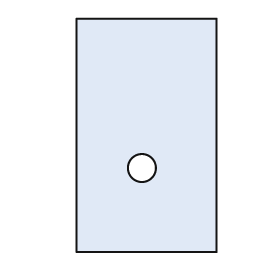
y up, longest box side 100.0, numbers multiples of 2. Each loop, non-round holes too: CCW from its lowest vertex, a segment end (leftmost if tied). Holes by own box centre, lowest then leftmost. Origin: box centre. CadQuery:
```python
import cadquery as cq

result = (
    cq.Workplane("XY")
    .moveTo(-30.0, -50.0)
    .lineTo(30.0, -50.0)
    .lineTo(30.0, 50.0)
    .lineTo(-30.0, 50.0)
    .close()
    .moveTo(-2.0, -14.0)
    .circle(6.0)
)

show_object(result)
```